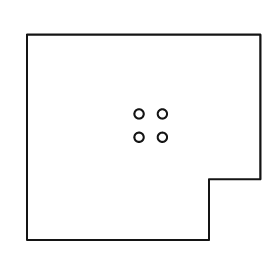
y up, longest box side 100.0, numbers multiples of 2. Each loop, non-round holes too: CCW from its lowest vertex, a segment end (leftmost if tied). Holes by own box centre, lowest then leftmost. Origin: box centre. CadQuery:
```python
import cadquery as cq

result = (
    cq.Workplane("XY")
    .moveTo(-50.0, -44.0)
    .lineTo(28.0, -44.0)
    .lineTo(28.0, -18.0)
    .lineTo(50.0, -18.0)
    .lineTo(50.0, 44.0)
    .lineTo(-50.0, 44.0)
    .close()
    .moveTo(-2.0, 0.0)
    .circle(2.0)
    .moveTo(8.0, 0.0)
    .circle(2.0)
    .moveTo(-2.0, 10.0)
    .circle(2.0)
    .moveTo(8.0, 10.0)
    .circle(2.0)
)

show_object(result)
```